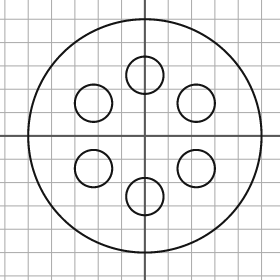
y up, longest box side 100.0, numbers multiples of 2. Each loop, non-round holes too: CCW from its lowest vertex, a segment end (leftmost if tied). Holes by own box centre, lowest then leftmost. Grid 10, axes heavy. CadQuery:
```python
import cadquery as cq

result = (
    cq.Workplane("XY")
    .moveTo(0.0, 0.0)
    .circle(50.0)
    .moveTo(0.0, -26.0)
    .circle(8.0)
    .moveTo(-22.0, -14.0)
    .circle(8.0)
    .moveTo(22.0, -14.0)
    .circle(8.0)
    .moveTo(-22.0, 14.0)
    .circle(8.0)
    .moveTo(22.0, 14.0)
    .circle(8.0)
    .moveTo(0.0, 26.0)
    .circle(8.0)
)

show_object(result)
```